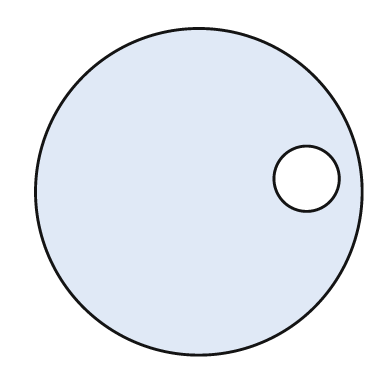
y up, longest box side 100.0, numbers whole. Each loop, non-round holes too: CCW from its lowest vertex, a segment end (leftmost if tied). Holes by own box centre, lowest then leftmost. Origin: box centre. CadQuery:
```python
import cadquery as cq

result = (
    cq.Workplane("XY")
    .moveTo(0.0, 0.0)
    .circle(50.0)
    .moveTo(33.0, 4.0)
    .circle(10.0)
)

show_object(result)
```